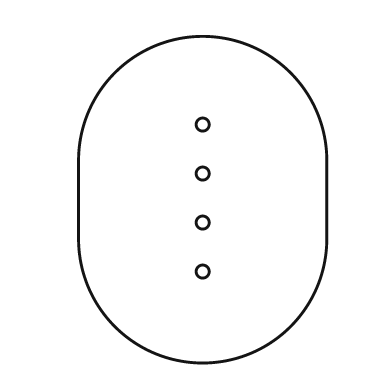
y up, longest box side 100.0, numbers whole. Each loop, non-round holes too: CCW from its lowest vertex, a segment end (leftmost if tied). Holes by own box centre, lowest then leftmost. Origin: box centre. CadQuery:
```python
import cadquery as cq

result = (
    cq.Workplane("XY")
    .moveTo(-38.0, -12.0)
    .threePointArc((0.0, -50.0), (38.0, -12.0))
    .lineTo(38.0, 12.0)
    .threePointArc((0.0, 50.0), (-38.0, 12.0))
    .close()
    .moveTo(0.0, -22.0)
    .circle(2.0)
    .moveTo(0.0, -7.0)
    .circle(2.0)
    .moveTo(0.0, 8.0)
    .circle(2.0)
    .moveTo(0.0, 23.0)
    .circle(2.0)
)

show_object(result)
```